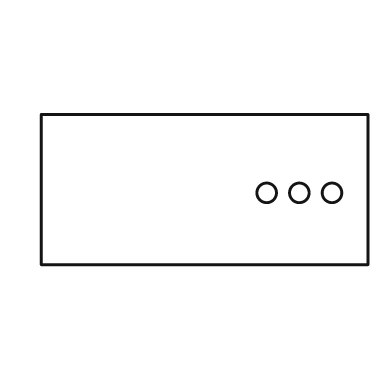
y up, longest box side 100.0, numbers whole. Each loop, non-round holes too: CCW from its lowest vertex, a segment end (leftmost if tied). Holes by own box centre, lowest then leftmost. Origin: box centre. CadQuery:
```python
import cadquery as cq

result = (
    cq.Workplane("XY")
    .moveTo(-50.0, -23.0)
    .lineTo(50.0, -23.0)
    .lineTo(50.0, 23.0)
    .lineTo(-50.0, 23.0)
    .close()
    .moveTo(19.0, -1.0)
    .circle(3.0)
    .moveTo(29.0, -1.0)
    .circle(3.0)
    .moveTo(39.0, -1.0)
    .circle(3.0)
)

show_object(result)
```